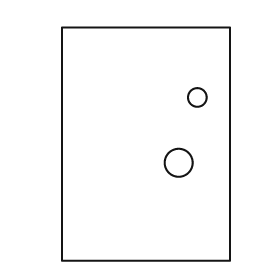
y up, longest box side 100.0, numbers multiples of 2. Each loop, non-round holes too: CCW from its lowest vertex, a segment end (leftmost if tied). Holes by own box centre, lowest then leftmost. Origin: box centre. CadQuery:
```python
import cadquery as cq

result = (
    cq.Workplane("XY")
    .moveTo(-36.0, -50.0)
    .lineTo(36.0, -50.0)
    .lineTo(36.0, 50.0)
    .lineTo(-36.0, 50.0)
    .close()
    .moveTo(14.0, -8.0)
    .circle(6.0)
    .moveTo(22.0, 20.0)
    .circle(4.0)
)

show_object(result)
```